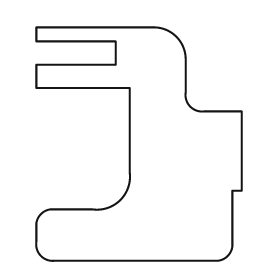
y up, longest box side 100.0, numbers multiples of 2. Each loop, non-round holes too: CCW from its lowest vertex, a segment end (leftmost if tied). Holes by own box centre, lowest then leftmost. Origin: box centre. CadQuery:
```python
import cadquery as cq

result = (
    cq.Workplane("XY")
    .moveTo(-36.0, -50.0)
    .lineTo(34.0, -50.0)
    .threePointArc((38.0, -48.0), (40.0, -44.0))
    .lineTo(40.0, -20.0)
    .lineTo(44.0, -20.0)
    .lineTo(44.0, 14.0)
    .lineTo(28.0, 14.0)
    .threePointArc((22.0, 16.0), (20.0, 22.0))
    .lineTo(20.0, 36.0)
    .threePointArc((16.0, 46.0), (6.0, 50.0))
    .lineTo(-44.0, 50.0)
    .lineTo(-44.0, 44.0)
    .lineTo(-10.0, 44.0)
    .lineTo(-10.0, 34.0)
    .lineTo(-44.0, 34.0)
    .lineTo(-44.0, 24.0)
    .lineTo(-4.0, 24.0)
    .lineTo(-4.0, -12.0)
    .threePointArc((-8.0, -24.0), (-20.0, -28.0))
    .lineTo(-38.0, -28.0)
    .threePointArc((-42.0, -30.0), (-44.0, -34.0))
    .lineTo(-44.0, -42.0)
    .threePointArc((-42.0, -48.0), (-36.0, -50.0))
    .close()
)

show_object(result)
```